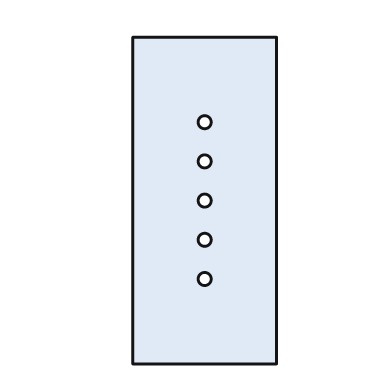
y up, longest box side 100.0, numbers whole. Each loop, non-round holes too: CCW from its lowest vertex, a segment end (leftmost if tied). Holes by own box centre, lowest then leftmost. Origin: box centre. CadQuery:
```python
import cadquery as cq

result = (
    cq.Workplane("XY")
    .moveTo(-22.0, -50.0)
    .lineTo(22.0, -50.0)
    .lineTo(22.0, 50.0)
    .lineTo(-22.0, 50.0)
    .close()
    .moveTo(0.0, -24.0)
    .circle(2.0)
    .moveTo(0.0, -12.0)
    .circle(2.0)
    .moveTo(0.0, 0.0)
    .circle(2.0)
    .moveTo(0.0, 12.0)
    .circle(2.0)
    .moveTo(0.0, 24.0)
    .circle(2.0)
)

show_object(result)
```